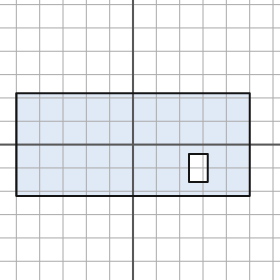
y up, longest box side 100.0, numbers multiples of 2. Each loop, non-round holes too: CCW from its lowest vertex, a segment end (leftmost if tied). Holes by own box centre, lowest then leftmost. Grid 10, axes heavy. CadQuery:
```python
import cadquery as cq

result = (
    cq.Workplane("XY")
    .moveTo(-50.0, -22.0)
    .lineTo(50.0, -22.0)
    .lineTo(50.0, 22.0)
    .lineTo(-50.0, 22.0)
    .close()
    .moveTo(24.0, -16.0)
    .lineTo(32.0, -16.0)
    .lineTo(32.0, -4.0)
    .lineTo(24.0, -4.0)
    .close()
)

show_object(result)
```